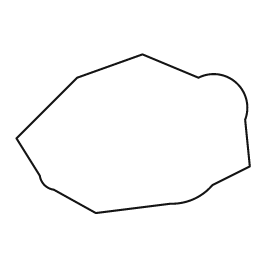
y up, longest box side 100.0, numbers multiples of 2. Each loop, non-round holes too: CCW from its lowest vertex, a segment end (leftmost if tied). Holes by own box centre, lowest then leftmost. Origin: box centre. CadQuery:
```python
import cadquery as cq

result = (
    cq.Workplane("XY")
    .moveTo(-16.0, -34.0)
    .lineTo(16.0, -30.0)
    .threePointArc((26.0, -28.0), (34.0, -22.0))
    .lineTo(50.0, -14.0)
    .lineTo(48.0, 6.0)
    .threePointArc((44.0, 22.0), (28.0, 24.0))
    .lineTo(4.0, 34.0)
    .lineTo(-24.0, 24.0)
    .lineTo(-50.0, -2.0)
    .lineTo(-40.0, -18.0)
    .threePointArc((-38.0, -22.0), (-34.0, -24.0))
    .close()
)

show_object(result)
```